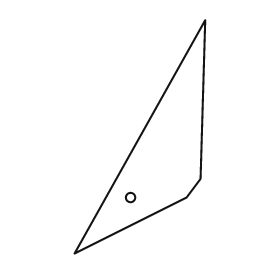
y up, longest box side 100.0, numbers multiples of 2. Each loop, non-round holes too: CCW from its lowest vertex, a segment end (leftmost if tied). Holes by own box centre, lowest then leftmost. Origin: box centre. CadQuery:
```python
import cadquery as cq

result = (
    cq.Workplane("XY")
    .moveTo(-28.0, -50.0)
    .lineTo(20.0, -26.0)
    .lineTo(26.0, -18.0)
    .lineTo(28.0, 50.0)
    .close()
    .moveTo(-4.0, -26.0)
    .circle(2.0)
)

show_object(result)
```